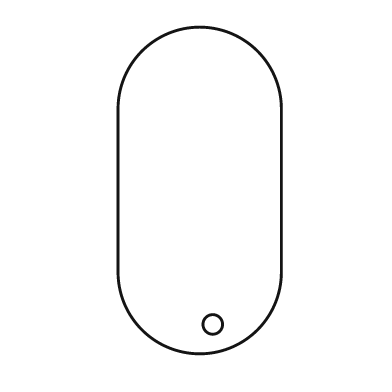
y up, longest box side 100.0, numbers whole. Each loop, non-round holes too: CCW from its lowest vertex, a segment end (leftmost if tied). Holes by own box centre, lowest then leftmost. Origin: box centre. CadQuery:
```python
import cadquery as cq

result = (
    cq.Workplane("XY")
    .moveTo(-25.0, -25.0)
    .threePointArc((0.0, -50.0), (25.0, -25.0))
    .lineTo(25.0, 25.0)
    .threePointArc((0.0, 50.0), (-25.0, 25.0))
    .close()
    .moveTo(4.0, -41.0)
    .circle(3.0)
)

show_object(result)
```